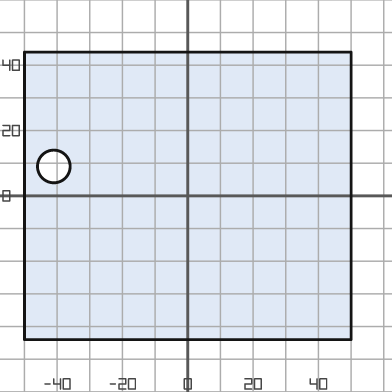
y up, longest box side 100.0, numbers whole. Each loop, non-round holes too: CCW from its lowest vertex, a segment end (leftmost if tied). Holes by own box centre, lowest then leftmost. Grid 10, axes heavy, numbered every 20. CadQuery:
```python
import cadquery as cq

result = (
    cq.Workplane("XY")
    .moveTo(-50.0, -44.0)
    .lineTo(50.0, -44.0)
    .lineTo(50.0, 44.0)
    .lineTo(-50.0, 44.0)
    .close()
    .moveTo(-41.0, 9.0)
    .circle(5.0)
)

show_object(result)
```